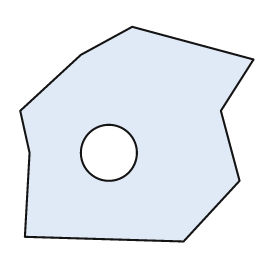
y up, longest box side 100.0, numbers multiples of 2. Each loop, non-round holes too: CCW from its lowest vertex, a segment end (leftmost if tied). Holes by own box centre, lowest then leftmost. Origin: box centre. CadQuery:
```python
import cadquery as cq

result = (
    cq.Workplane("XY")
    .moveTo(20.0, -46.0)
    .lineTo(44.0, -20.0)
    .lineTo(36.0, 10.0)
    .lineTo(50.0, 32.0)
    .lineTo(-2.0, 46.0)
    .lineTo(-24.0, 34.0)
    .lineTo(-50.0, 10.0)
    .lineTo(-46.0, -8.0)
    .lineTo(-48.0, -44.0)
    .close()
    .moveTo(-12.0, -8.0)
    .circle(12.0)
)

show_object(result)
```